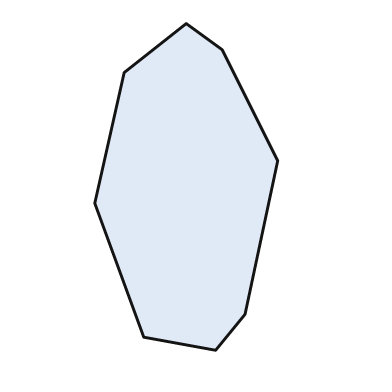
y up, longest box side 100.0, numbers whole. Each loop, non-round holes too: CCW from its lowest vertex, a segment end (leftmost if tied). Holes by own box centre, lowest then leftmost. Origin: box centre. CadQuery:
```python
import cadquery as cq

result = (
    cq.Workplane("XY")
    .moveTo(9.0, -50.0)
    .lineTo(18.0, -39.0)
    .lineTo(28.0, 8.0)
    .lineTo(11.0, 42.0)
    .lineTo(0.0, 50.0)
    .lineTo(-19.0, 35.0)
    .lineTo(-28.0, -5.0)
    .lineTo(-13.0, -46.0)
    .close()
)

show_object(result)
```